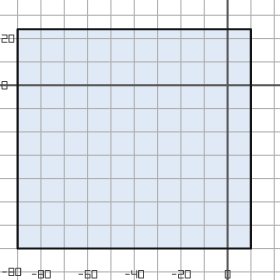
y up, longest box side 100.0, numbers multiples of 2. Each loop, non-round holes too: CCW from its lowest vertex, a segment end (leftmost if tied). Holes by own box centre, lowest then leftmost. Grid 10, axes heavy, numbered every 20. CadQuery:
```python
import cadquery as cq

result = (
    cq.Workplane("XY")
    .moveTo(-90.0, -70.0)
    .lineTo(10.0, -70.0)
    .lineTo(10.0, 24.0)
    .lineTo(-90.0, 24.0)
    .close()
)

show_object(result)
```